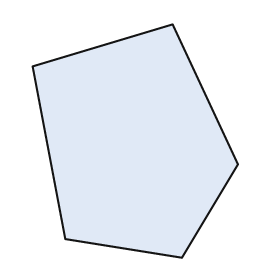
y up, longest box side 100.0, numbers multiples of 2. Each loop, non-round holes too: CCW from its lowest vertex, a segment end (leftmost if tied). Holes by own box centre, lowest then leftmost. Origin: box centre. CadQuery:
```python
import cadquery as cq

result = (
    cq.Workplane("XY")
    .moveTo(20.0, -50.0)
    .lineTo(44.0, -10.0)
    .lineTo(16.0, 50.0)
    .lineTo(-44.0, 32.0)
    .lineTo(-30.0, -42.0)
    .close()
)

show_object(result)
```